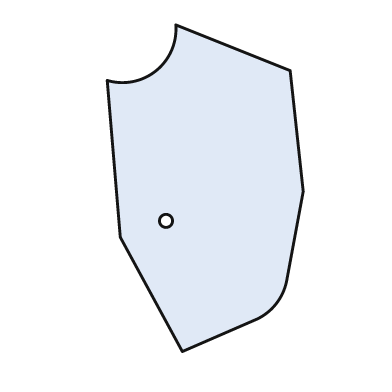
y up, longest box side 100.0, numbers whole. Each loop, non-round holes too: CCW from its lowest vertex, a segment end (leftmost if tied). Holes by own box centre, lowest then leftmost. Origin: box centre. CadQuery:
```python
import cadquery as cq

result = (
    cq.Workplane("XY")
    .moveTo(-7.0, -50.0)
    .lineTo(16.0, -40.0)
    .threePointArc((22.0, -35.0), (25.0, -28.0))
    .lineTo(30.0, -1.0)
    .lineTo(26.0, 36.0)
    .lineTo(-9.0, 50.0)
    .threePointArc((-15.0, 36.0), (-30.0, 33.0))
    .lineTo(-26.0, -15.0)
    .close()
    .moveTo(-12.0, -10.0)
    .circle(2.0)
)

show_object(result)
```